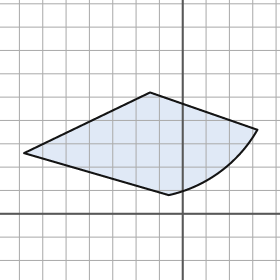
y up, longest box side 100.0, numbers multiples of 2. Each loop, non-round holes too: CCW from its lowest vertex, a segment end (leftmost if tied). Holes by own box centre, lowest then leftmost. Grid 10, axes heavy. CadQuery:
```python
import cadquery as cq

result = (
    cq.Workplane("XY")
    .moveTo(-6.0, 8.0)
    .threePointArc((16.0, 18.0), (32.0, 36.0))
    .lineTo(-14.0, 52.0)
    .lineTo(-68.0, 26.0)
    .close()
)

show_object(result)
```